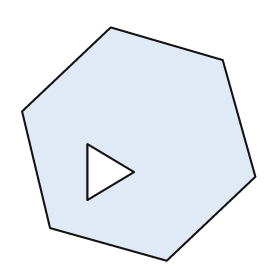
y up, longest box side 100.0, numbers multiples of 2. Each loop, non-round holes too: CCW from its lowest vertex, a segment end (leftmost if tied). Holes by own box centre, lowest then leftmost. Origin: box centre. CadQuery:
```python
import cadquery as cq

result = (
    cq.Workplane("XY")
    .moveTo(12.0, -50.0)
    .lineTo(50.0, -14.0)
    .lineTo(36.0, 36.0)
    .lineTo(-12.0, 50.0)
    .lineTo(-50.0, 14.0)
    .lineTo(-38.0, -36.0)
    .close()
    .moveTo(-22.0, -24.0)
    .lineTo(-2.0, -12.0)
    .lineTo(-22.0, 0.0)
    .close()
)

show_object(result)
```